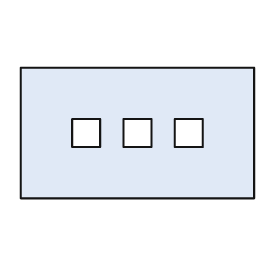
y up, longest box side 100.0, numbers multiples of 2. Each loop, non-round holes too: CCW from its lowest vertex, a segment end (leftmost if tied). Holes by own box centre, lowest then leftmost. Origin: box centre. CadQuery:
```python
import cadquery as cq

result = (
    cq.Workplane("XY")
    .moveTo(-50.0, -28.0)
    .lineTo(50.0, -28.0)
    .lineTo(50.0, 28.0)
    .lineTo(-50.0, 28.0)
    .close()
    .moveTo(-28.0, -6.0)
    .lineTo(-16.0, -6.0)
    .lineTo(-16.0, 6.0)
    .lineTo(-28.0, 6.0)
    .close()
    .moveTo(-6.0, -6.0)
    .lineTo(6.0, -6.0)
    .lineTo(6.0, 6.0)
    .lineTo(-6.0, 6.0)
    .close()
    .moveTo(16.0, -6.0)
    .lineTo(28.0, -6.0)
    .lineTo(28.0, 6.0)
    .lineTo(16.0, 6.0)
    .close()
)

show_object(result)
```